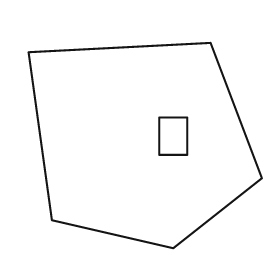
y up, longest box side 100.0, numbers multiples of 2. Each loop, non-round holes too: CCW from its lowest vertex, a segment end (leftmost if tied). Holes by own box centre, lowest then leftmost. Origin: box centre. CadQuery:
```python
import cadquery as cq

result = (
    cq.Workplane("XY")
    .moveTo(12.0, -44.0)
    .lineTo(50.0, -14.0)
    .lineTo(28.0, 44.0)
    .lineTo(-50.0, 40.0)
    .lineTo(-40.0, -32.0)
    .close()
    .moveTo(6.0, -4.0)
    .lineTo(18.0, -4.0)
    .lineTo(18.0, 12.0)
    .lineTo(6.0, 12.0)
    .close()
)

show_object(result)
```